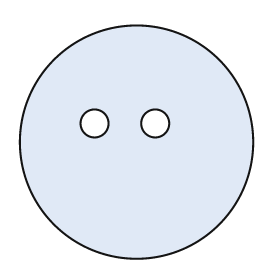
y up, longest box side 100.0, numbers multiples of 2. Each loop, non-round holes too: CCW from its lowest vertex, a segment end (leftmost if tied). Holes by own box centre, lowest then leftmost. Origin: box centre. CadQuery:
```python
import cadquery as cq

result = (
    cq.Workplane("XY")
    .moveTo(0.0, 0.0)
    .circle(50.0)
    .moveTo(-18.0, 8.0)
    .circle(6.0)
    .moveTo(8.0, 8.0)
    .circle(6.0)
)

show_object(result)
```